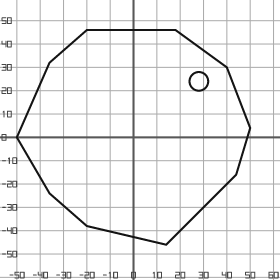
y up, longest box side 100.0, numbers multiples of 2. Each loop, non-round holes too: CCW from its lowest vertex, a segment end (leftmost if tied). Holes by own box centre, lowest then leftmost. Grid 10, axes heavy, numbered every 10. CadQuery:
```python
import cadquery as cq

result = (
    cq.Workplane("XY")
    .moveTo(14.0, -46.0)
    .lineTo(44.0, -16.0)
    .lineTo(50.0, 4.0)
    .lineTo(40.0, 30.0)
    .lineTo(18.0, 46.0)
    .lineTo(-20.0, 46.0)
    .lineTo(-36.0, 32.0)
    .lineTo(-50.0, 0.0)
    .lineTo(-36.0, -24.0)
    .lineTo(-20.0, -38.0)
    .close()
    .moveTo(28.0, 24.0)
    .circle(4.0)
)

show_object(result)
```